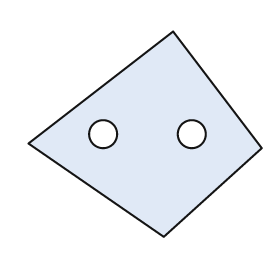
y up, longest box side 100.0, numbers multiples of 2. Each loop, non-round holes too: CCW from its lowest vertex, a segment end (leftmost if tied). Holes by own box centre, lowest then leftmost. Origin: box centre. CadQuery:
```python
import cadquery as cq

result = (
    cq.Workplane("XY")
    .moveTo(8.0, -44.0)
    .lineTo(50.0, -6.0)
    .lineTo(12.0, 44.0)
    .lineTo(-50.0, -4.0)
    .close()
    .moveTo(-18.0, 0.0)
    .circle(6.0)
    .moveTo(20.0, 0.0)
    .circle(6.0)
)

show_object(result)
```